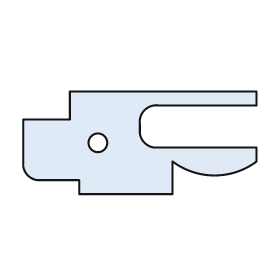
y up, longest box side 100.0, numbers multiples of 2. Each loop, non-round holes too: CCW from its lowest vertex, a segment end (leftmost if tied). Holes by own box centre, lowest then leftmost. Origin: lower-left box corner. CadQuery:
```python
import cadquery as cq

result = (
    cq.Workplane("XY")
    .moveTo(24.0, 0.0)
    .lineTo(64.0, 0.0)
    .lineTo(64.0, 14.0)
    .threePointArc((82.0, 8.0), (100.0, 14.0))
    .lineTo(100.0, 20.0)
    .lineTo(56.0, 20.0)
    .threePointArc((52.0, 22.0), (50.0, 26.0))
    .lineTo(50.0, 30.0)
    .threePointArc((52.0, 36.0), (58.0, 38.0))
    .lineTo(100.0, 38.0)
    .lineTo(100.0, 44.0)
    .lineTo(20.0, 44.0)
    .lineTo(20.0, 32.0)
    .lineTo(0.0, 32.0)
    .lineTo(0.0, 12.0)
    .threePointArc((2.0, 8.0), (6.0, 6.0))
    .lineTo(24.0, 6.0)
    .close()
    .moveTo(32.0, 22.0)
    .circle(4.0)
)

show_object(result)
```